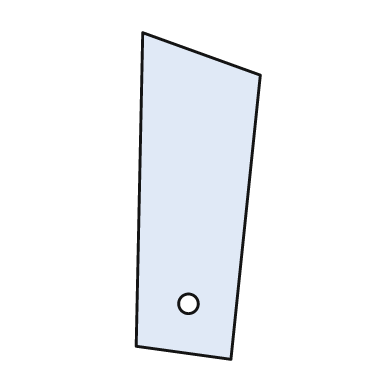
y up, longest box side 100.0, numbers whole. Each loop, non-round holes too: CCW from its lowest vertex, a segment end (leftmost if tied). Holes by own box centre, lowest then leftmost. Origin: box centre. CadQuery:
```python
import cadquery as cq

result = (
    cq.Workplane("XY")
    .moveTo(10.0, -50.0)
    .lineTo(19.0, 37.0)
    .lineTo(-17.0, 50.0)
    .lineTo(-19.0, -46.0)
    .close()
    .moveTo(-3.0, -33.0)
    .circle(3.0)
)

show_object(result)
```